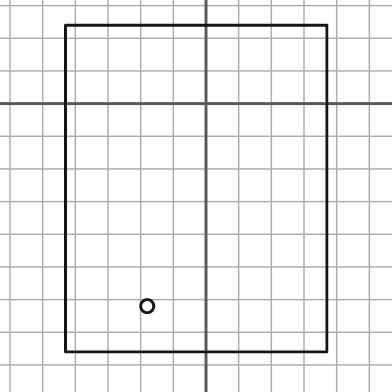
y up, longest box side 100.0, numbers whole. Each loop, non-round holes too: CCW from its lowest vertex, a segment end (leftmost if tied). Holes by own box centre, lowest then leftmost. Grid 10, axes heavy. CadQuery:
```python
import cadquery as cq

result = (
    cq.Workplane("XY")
    .moveTo(-43.0, -76.0)
    .lineTo(37.0, -76.0)
    .lineTo(37.0, 24.0)
    .lineTo(-43.0, 24.0)
    .close()
    .moveTo(-18.0, -62.0)
    .circle(2.0)
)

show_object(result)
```